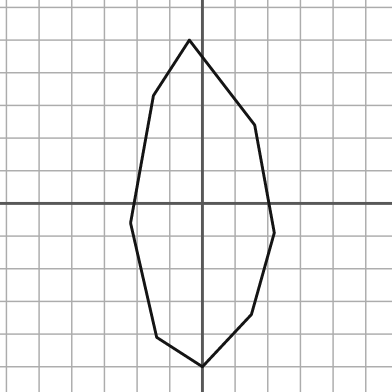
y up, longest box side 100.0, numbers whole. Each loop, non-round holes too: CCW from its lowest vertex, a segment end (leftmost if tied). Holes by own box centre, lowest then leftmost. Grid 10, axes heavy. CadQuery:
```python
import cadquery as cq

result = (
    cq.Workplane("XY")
    .moveTo(0.0, -50.0)
    .lineTo(15.0, -34.0)
    .lineTo(22.0, -9.0)
    .lineTo(16.0, 24.0)
    .lineTo(-4.0, 50.0)
    .lineTo(-15.0, 33.0)
    .lineTo(-22.0, -6.0)
    .lineTo(-14.0, -41.0)
    .close()
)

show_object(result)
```